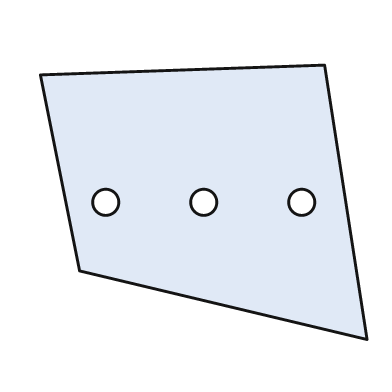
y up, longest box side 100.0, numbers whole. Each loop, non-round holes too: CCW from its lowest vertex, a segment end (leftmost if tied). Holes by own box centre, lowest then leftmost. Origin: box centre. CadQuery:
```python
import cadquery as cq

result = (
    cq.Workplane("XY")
    .moveTo(50.0, -42.0)
    .lineTo(37.0, 42.0)
    .lineTo(-50.0, 39.0)
    .lineTo(-38.0, -21.0)
    .close()
    .moveTo(-30.0, 0.0)
    .circle(4.0)
    .moveTo(0.0, 0.0)
    .circle(4.0)
    .moveTo(30.0, 0.0)
    .circle(4.0)
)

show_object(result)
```